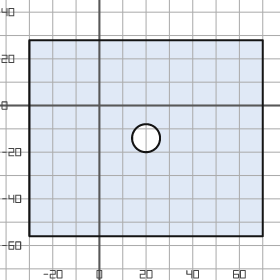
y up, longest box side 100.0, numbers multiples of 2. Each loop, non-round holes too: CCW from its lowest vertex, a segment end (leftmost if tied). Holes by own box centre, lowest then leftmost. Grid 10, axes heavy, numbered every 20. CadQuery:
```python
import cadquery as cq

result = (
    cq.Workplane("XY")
    .moveTo(-30.0, -56.0)
    .lineTo(70.0, -56.0)
    .lineTo(70.0, 28.0)
    .lineTo(-30.0, 28.0)
    .close()
    .moveTo(20.0, -14.0)
    .circle(6.0)
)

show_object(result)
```